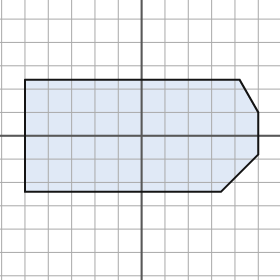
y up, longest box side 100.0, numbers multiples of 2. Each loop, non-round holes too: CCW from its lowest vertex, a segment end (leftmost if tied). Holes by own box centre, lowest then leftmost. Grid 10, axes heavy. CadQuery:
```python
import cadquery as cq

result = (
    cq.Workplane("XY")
    .moveTo(-50.0, -24.0)
    .lineTo(34.0, -24.0)
    .lineTo(50.0, -8.0)
    .lineTo(50.0, 10.0)
    .lineTo(42.0, 24.0)
    .lineTo(-50.0, 24.0)
    .close()
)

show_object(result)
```